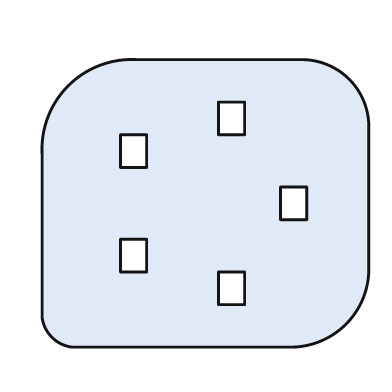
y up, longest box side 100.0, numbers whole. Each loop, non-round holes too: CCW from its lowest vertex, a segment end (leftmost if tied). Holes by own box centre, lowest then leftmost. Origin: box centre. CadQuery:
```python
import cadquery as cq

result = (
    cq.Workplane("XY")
    .moveTo(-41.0, -44.0)
    .lineTo(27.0, -44.0)
    .threePointArc((43.0, -37.0), (50.0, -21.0))
    .lineTo(50.0, 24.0)
    .threePointArc((44.0, 38.0), (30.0, 44.0))
    .lineTo(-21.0, 44.0)
    .threePointArc((-42.0, 36.0), (-50.0, 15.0))
    .lineTo(-50.0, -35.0)
    .threePointArc((-47.0, -41.0), (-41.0, -44.0))
    .close()
    .moveTo(4.0, -31.0)
    .lineTo(12.0, -31.0)
    .lineTo(12.0, -21.0)
    .lineTo(4.0, -21.0)
    .close()
    .moveTo(-26.0, -21.0)
    .lineTo(-18.0, -21.0)
    .lineTo(-18.0, -11.0)
    .lineTo(-26.0, -11.0)
    .close()
    .moveTo(23.0, -5.0)
    .lineTo(31.0, -5.0)
    .lineTo(31.0, 5.0)
    .lineTo(23.0, 5.0)
    .close()
    .moveTo(-26.0, 11.0)
    .lineTo(-18.0, 11.0)
    .lineTo(-18.0, 21.0)
    .lineTo(-26.0, 21.0)
    .close()
    .moveTo(4.0, 21.0)
    .lineTo(12.0, 21.0)
    .lineTo(12.0, 31.0)
    .lineTo(4.0, 31.0)
    .close()
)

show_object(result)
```